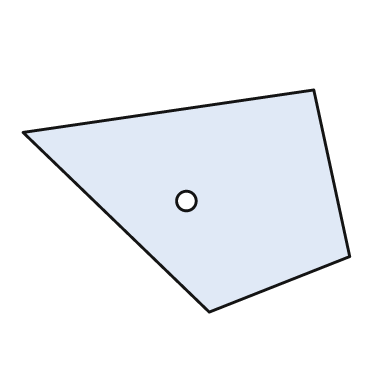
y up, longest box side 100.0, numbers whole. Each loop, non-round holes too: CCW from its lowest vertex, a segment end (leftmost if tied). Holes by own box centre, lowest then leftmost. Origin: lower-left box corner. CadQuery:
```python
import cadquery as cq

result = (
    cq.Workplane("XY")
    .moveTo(57.0, 0.0)
    .lineTo(100.0, 17.0)
    .lineTo(89.0, 68.0)
    .lineTo(0.0, 55.0)
    .close()
    .moveTo(50.0, 34.0)
    .circle(3.0)
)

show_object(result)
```